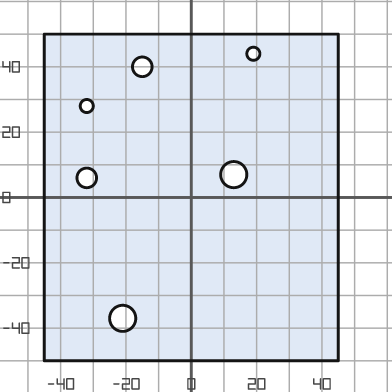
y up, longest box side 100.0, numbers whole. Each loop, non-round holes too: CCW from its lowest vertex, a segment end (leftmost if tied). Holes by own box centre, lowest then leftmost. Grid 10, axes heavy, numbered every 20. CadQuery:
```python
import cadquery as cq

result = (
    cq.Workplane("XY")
    .moveTo(-45.0, -50.0)
    .lineTo(45.0, -50.0)
    .lineTo(45.0, 50.0)
    .lineTo(-45.0, 50.0)
    .close()
    .moveTo(-21.0, -37.0)
    .circle(4.0)
    .moveTo(-32.0, 6.0)
    .circle(3.0)
    .moveTo(13.0, 7.0)
    .circle(4.0)
    .moveTo(-32.0, 28.0)
    .circle(2.0)
    .moveTo(-15.0, 40.0)
    .circle(3.0)
    .moveTo(19.0, 44.0)
    .circle(2.0)
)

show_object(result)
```